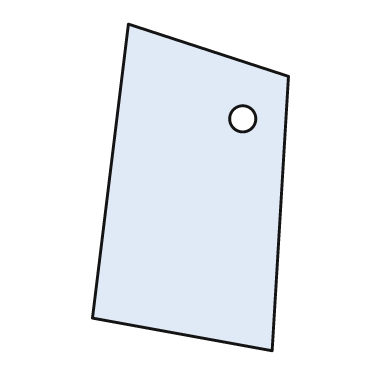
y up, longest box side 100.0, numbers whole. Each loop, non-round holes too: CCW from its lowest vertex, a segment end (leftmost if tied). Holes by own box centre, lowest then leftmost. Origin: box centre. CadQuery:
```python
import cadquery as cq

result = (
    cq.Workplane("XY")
    .moveTo(25.0, -50.0)
    .lineTo(30.0, 34.0)
    .lineTo(-19.0, 50.0)
    .lineTo(-30.0, -40.0)
    .close()
    .moveTo(16.0, 21.0)
    .circle(4.0)
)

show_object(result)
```